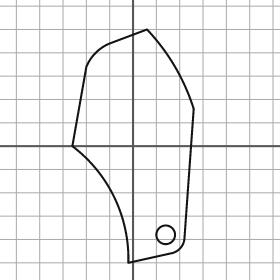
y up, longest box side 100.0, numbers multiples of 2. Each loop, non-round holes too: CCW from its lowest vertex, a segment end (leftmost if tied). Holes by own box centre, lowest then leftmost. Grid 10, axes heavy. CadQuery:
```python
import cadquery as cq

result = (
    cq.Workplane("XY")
    .moveTo(-2.0, -50.0)
    .lineTo(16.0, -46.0)
    .threePointArc((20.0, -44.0), (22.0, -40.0))
    .lineTo(26.0, 16.0)
    .threePointArc((18.0, 34.0), (6.0, 50.0))
    .lineTo(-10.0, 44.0)
    .threePointArc((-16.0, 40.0), (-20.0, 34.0))
    .lineTo(-26.0, 0.0)
    .threePointArc((-8.0, -22.0), (-2.0, -50.0))
    .close()
    .moveTo(14.0, -38.0)
    .circle(4.0)
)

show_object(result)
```